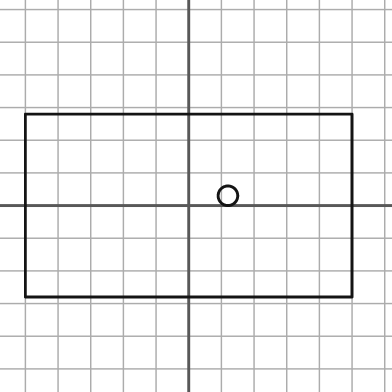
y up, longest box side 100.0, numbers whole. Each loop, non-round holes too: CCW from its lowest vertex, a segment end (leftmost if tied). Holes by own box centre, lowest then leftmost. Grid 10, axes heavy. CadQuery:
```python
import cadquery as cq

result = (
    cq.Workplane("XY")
    .moveTo(-50.0, -28.0)
    .lineTo(50.0, -28.0)
    .lineTo(50.0, 28.0)
    .lineTo(-50.0, 28.0)
    .close()
    .moveTo(12.0, 3.0)
    .circle(3.0)
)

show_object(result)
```